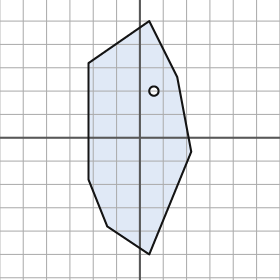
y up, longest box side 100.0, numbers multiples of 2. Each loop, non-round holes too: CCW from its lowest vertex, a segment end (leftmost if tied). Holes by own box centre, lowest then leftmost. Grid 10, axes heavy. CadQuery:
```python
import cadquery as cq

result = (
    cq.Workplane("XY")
    .moveTo(4.0, -50.0)
    .lineTo(22.0, -6.0)
    .lineTo(16.0, 26.0)
    .lineTo(4.0, 50.0)
    .lineTo(-22.0, 32.0)
    .lineTo(-22.0, -18.0)
    .lineTo(-14.0, -38.0)
    .close()
    .moveTo(6.0, 20.0)
    .circle(2.0)
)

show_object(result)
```